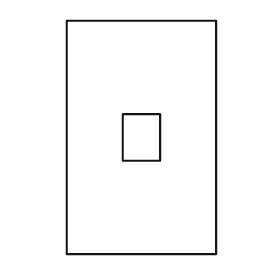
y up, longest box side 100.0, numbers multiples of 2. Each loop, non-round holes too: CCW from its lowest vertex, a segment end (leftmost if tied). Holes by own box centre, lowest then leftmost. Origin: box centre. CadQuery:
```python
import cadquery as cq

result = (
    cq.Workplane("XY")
    .moveTo(-32.0, -50.0)
    .lineTo(32.0, -50.0)
    .lineTo(32.0, 50.0)
    .lineTo(-32.0, 50.0)
    .close()
    .moveTo(-8.0, -10.0)
    .lineTo(8.0, -10.0)
    .lineTo(8.0, 10.0)
    .lineTo(-8.0, 10.0)
    .close()
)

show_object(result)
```